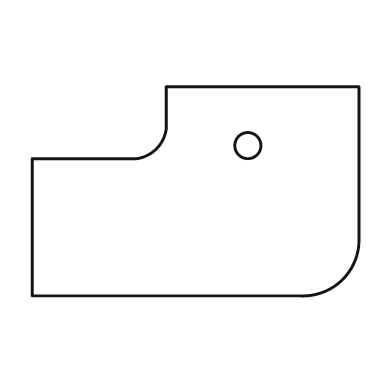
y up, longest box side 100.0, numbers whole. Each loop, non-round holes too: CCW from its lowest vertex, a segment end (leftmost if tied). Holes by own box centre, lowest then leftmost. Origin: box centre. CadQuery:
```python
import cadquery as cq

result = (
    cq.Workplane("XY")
    .moveTo(-50.0, -32.0)
    .lineTo(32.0, -32.0)
    .threePointArc((45.0, -27.0), (50.0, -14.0))
    .lineTo(50.0, 32.0)
    .lineTo(-9.0, 32.0)
    .lineTo(-9.0, 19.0)
    .threePointArc((-12.0, 13.0), (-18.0, 10.0))
    .lineTo(-50.0, 10.0)
    .close()
    .moveTo(16.0, 14.0)
    .circle(4.0)
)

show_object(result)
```